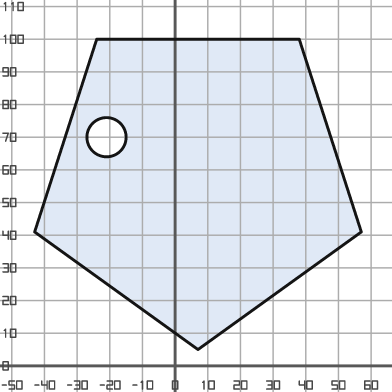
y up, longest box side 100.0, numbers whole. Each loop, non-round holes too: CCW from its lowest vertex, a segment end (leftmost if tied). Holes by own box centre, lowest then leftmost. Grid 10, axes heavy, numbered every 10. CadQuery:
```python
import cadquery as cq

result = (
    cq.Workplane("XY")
    .moveTo(7.0, 5.0)
    .lineTo(57.0, 41.0)
    .lineTo(38.0, 100.0)
    .lineTo(-24.0, 100.0)
    .lineTo(-43.0, 41.0)
    .close()
    .moveTo(-21.0, 70.0)
    .circle(6.0)
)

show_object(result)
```